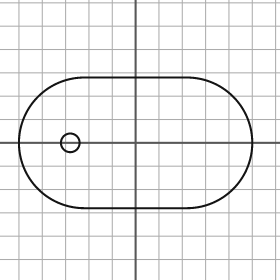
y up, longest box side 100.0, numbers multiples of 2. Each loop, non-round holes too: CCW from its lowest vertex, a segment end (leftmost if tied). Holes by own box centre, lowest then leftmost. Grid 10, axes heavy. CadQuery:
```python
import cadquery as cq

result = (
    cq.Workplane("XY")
    .moveTo(-22.0, -28.0)
    .lineTo(22.0, -28.0)
    .threePointArc((50.0, 0.0), (22.0, 28.0))
    .lineTo(-22.0, 28.0)
    .threePointArc((-50.0, 0.0), (-22.0, -28.0))
    .close()
    .moveTo(-28.0, 0.0)
    .circle(4.0)
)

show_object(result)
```